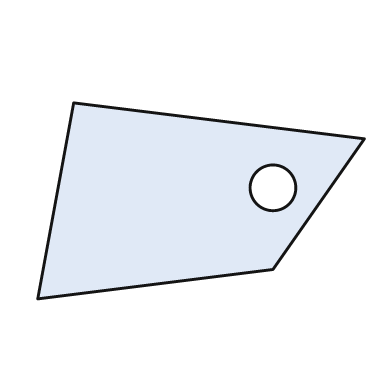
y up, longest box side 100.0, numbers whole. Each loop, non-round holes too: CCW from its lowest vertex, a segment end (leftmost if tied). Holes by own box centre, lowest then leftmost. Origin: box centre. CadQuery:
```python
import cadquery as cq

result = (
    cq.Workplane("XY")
    .moveTo(-50.0, -30.0)
    .lineTo(22.0, -21.0)
    .lineTo(50.0, 19.0)
    .lineTo(-39.0, 30.0)
    .close()
    .moveTo(22.0, 4.0)
    .circle(7.0)
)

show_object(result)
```